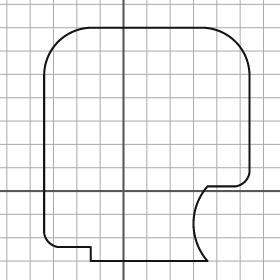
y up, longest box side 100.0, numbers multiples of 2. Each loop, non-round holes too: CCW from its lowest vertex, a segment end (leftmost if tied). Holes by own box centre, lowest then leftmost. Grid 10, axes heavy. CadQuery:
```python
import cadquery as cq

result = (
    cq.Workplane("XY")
    .moveTo(-14.0, -30.0)
    .lineTo(36.0, -30.0)
    .threePointArc((30.0, -14.0), (36.0, 2.0))
    .lineTo(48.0, 2.0)
    .threePointArc((52.0, 4.0), (54.0, 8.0))
    .lineTo(54.0, 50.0)
    .threePointArc((48.0, 64.0), (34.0, 70.0))
    .lineTo(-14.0, 70.0)
    .threePointArc((-28.0, 64.0), (-34.0, 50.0))
    .lineTo(-34.0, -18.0)
    .threePointArc((-32.0, -22.0), (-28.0, -24.0))
    .lineTo(-14.0, -24.0)
    .close()
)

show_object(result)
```